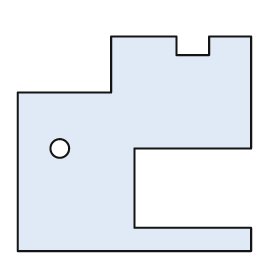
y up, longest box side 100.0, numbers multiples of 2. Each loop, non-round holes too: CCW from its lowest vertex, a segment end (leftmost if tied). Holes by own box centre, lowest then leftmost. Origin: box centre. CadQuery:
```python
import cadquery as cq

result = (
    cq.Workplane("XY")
    .moveTo(-50.0, -46.0)
    .lineTo(50.0, -46.0)
    .lineTo(50.0, -36.0)
    .lineTo(0.0, -36.0)
    .lineTo(0.0, -2.0)
    .lineTo(50.0, -2.0)
    .lineTo(50.0, 46.0)
    .lineTo(32.0, 46.0)
    .lineTo(32.0, 38.0)
    .lineTo(18.0, 38.0)
    .lineTo(18.0, 46.0)
    .lineTo(-10.0, 46.0)
    .lineTo(-10.0, 22.0)
    .lineTo(-50.0, 22.0)
    .close()
    .moveTo(-32.0, -2.0)
    .circle(4.0)
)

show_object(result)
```